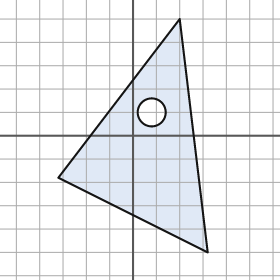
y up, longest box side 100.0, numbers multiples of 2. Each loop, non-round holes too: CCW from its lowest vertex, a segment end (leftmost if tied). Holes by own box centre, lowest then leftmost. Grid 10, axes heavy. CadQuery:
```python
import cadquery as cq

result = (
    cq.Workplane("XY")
    .moveTo(32.0, -50.0)
    .lineTo(20.0, 50.0)
    .lineTo(-32.0, -18.0)
    .close()
    .moveTo(8.0, 10.0)
    .circle(6.0)
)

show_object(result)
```